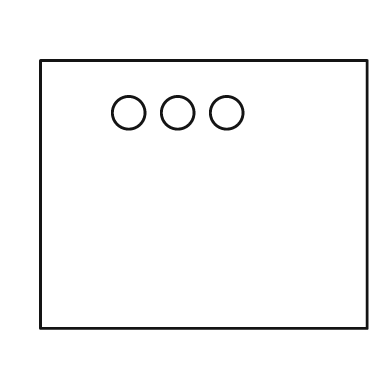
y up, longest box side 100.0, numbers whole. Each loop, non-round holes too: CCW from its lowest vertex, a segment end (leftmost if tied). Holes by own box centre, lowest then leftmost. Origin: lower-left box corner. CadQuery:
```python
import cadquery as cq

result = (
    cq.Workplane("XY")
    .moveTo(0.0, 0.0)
    .lineTo(100.0, 0.0)
    .lineTo(100.0, 82.0)
    .lineTo(0.0, 82.0)
    .close()
    .moveTo(27.0, 66.0)
    .circle(5.0)
    .moveTo(42.0, 66.0)
    .circle(5.0)
    .moveTo(57.0, 66.0)
    .circle(5.0)
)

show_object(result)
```